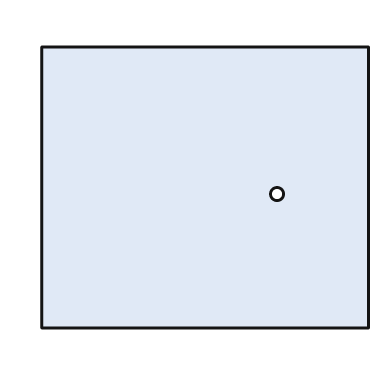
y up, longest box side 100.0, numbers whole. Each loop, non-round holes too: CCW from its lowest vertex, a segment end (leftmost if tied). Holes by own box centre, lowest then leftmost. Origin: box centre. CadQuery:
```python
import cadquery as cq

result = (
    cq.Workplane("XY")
    .moveTo(-50.0, -43.0)
    .lineTo(50.0, -43.0)
    .lineTo(50.0, 43.0)
    .lineTo(-50.0, 43.0)
    .close()
    .moveTo(22.0, -2.0)
    .circle(2.0)
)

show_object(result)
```